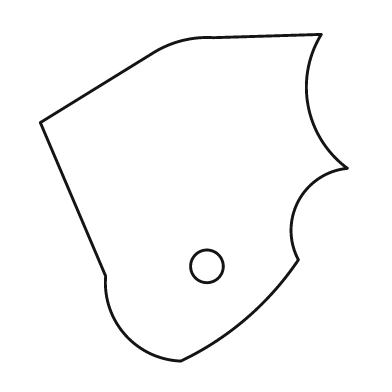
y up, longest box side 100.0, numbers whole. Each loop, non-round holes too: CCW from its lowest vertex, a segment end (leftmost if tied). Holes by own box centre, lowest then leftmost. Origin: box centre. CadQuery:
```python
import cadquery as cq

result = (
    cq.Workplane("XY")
    .moveTo(-4.0, -50.0)
    .threePointArc((16.0, -37.0), (32.0, -19.0))
    .threePointArc((32.0, -1.0), (47.0, 9.0))
    .threePointArc((35.0, 28.0), (39.0, 50.0))
    .lineTo(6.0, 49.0)
    .threePointArc((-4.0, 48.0), (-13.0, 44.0))
    .lineTo(-47.0, 23.0)
    .lineTo(-27.0, -24.0)
    .threePointArc((-21.0, -42.0), (-4.0, -50.0))
    .close()
    .moveTo(4.0, -21.0)
    .circle(5.0)
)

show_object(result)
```